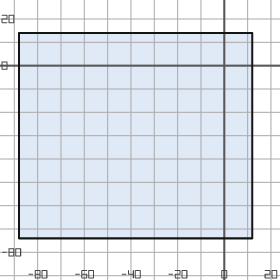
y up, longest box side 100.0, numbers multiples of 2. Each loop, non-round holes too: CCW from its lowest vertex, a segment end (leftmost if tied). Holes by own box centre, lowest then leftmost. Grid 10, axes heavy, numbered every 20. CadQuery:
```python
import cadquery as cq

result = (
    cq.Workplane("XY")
    .moveTo(-88.0, -74.0)
    .lineTo(12.0, -74.0)
    .lineTo(12.0, 14.0)
    .lineTo(-88.0, 14.0)
    .close()
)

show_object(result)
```